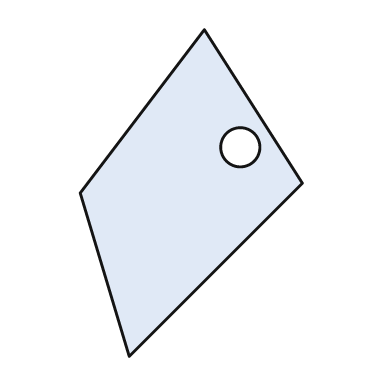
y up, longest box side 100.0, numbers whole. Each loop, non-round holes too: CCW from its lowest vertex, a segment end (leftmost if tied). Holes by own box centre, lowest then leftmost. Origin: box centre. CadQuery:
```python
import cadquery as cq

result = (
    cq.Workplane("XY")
    .moveTo(-19.0, -50.0)
    .lineTo(34.0, 3.0)
    .lineTo(4.0, 50.0)
    .lineTo(-34.0, 0.0)
    .close()
    .moveTo(15.0, 14.0)
    .circle(6.0)
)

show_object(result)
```